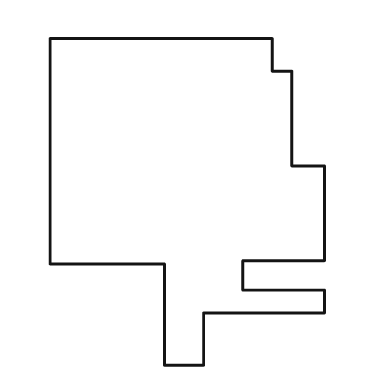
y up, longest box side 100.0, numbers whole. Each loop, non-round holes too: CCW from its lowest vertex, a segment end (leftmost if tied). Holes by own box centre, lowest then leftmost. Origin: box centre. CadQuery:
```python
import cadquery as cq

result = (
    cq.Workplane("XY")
    .moveTo(-7.0, -50.0)
    .lineTo(5.0, -50.0)
    .lineTo(5.0, -34.0)
    .lineTo(42.0, -34.0)
    .lineTo(42.0, -27.0)
    .lineTo(17.0, -27.0)
    .lineTo(17.0, -18.0)
    .lineTo(42.0, -18.0)
    .lineTo(42.0, 11.0)
    .lineTo(32.0, 11.0)
    .lineTo(32.0, 40.0)
    .lineTo(26.0, 40.0)
    .lineTo(26.0, 50.0)
    .lineTo(-42.0, 50.0)
    .lineTo(-42.0, -19.0)
    .lineTo(-7.0, -19.0)
    .close()
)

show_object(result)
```